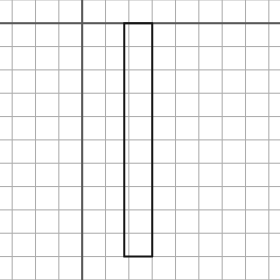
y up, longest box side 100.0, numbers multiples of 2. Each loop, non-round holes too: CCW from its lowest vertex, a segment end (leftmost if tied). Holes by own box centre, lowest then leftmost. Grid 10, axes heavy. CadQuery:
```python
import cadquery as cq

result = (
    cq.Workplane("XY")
    .moveTo(18.0, -100.0)
    .lineTo(30.0, -100.0)
    .lineTo(30.0, 0.0)
    .lineTo(18.0, 0.0)
    .close()
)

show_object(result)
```